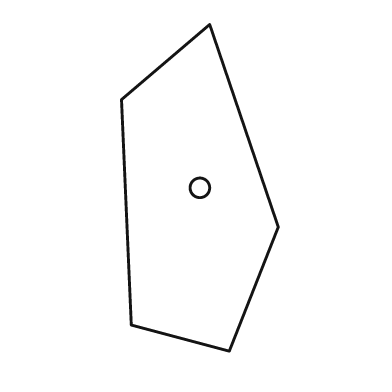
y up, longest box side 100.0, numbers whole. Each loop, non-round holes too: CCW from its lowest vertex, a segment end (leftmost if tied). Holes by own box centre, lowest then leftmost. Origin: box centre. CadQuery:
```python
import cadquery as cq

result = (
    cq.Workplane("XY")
    .moveTo(9.0, -50.0)
    .lineTo(24.0, -12.0)
    .lineTo(3.0, 50.0)
    .lineTo(-24.0, 27.0)
    .lineTo(-21.0, -42.0)
    .close()
    .moveTo(0.0, 0.0)
    .circle(3.0)
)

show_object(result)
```